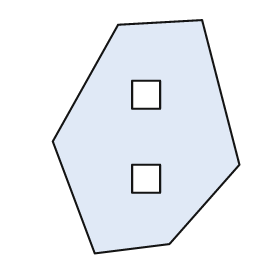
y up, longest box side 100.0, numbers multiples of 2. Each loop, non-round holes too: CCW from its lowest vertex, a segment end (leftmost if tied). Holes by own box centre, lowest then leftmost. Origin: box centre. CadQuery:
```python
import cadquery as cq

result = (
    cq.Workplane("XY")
    .moveTo(-22.0, -50.0)
    .lineTo(10.0, -46.0)
    .lineTo(40.0, -12.0)
    .lineTo(24.0, 50.0)
    .lineTo(-12.0, 48.0)
    .lineTo(-40.0, -2.0)
    .close()
    .moveTo(-6.0, -24.0)
    .lineTo(6.0, -24.0)
    .lineTo(6.0, -12.0)
    .lineTo(-6.0, -12.0)
    .close()
    .moveTo(-6.0, 12.0)
    .lineTo(6.0, 12.0)
    .lineTo(6.0, 24.0)
    .lineTo(-6.0, 24.0)
    .close()
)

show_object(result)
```